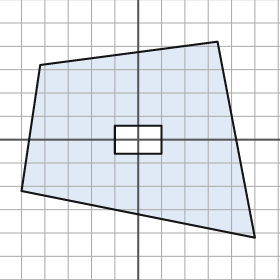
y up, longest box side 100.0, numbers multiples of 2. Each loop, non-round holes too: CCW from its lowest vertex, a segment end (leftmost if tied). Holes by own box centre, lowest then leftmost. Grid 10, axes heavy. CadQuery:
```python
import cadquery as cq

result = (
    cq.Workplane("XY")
    .moveTo(50.0, -42.0)
    .lineTo(34.0, 42.0)
    .lineTo(-42.0, 32.0)
    .lineTo(-50.0, -22.0)
    .close()
    .moveTo(-10.0, -6.0)
    .lineTo(10.0, -6.0)
    .lineTo(10.0, 6.0)
    .lineTo(-10.0, 6.0)
    .close()
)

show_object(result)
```